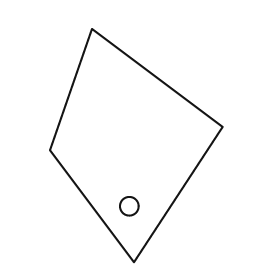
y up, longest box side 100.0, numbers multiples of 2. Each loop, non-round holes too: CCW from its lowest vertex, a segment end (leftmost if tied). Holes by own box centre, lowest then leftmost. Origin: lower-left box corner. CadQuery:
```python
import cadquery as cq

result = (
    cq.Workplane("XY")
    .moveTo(36.0, 0.0)
    .lineTo(74.0, 58.0)
    .lineTo(18.0, 100.0)
    .lineTo(0.0, 48.0)
    .close()
    .moveTo(34.0, 24.0)
    .circle(4.0)
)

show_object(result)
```